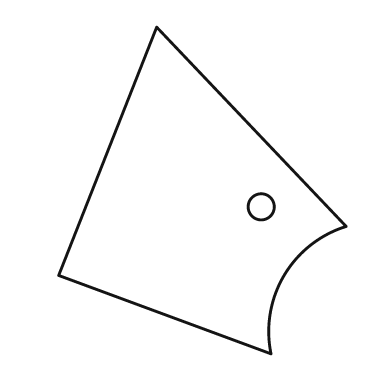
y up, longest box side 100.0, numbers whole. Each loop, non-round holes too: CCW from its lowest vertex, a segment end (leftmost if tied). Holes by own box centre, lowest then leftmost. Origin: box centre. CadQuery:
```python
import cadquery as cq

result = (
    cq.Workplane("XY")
    .moveTo(21.0, -50.0)
    .threePointArc((25.0, -26.0), (44.0, -11.0))
    .lineTo(-14.0, 50.0)
    .lineTo(-44.0, -26.0)
    .close()
    .moveTo(18.0, -5.0)
    .circle(4.0)
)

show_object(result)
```